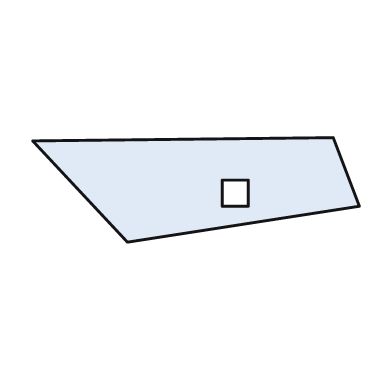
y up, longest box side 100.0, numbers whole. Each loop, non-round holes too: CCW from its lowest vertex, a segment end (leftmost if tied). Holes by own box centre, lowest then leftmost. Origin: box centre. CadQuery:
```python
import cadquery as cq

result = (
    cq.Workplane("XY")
    .moveTo(-21.0, -16.0)
    .lineTo(50.0, -5.0)
    .lineTo(42.0, 16.0)
    .lineTo(-50.0, 15.0)
    .close()
    .moveTo(8.0, -5.0)
    .lineTo(16.0, -5.0)
    .lineTo(16.0, 3.0)
    .lineTo(8.0, 3.0)
    .close()
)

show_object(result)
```